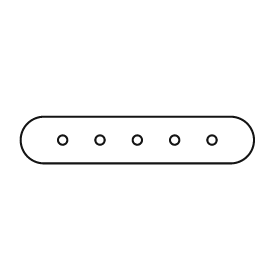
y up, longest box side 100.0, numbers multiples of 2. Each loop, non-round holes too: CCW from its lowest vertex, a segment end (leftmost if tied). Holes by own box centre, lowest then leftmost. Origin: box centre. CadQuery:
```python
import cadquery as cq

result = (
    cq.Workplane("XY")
    .moveTo(-40.0, -10.0)
    .lineTo(40.0, -10.0)
    .threePointArc((50.0, 0.0), (40.0, 10.0))
    .lineTo(-40.0, 10.0)
    .threePointArc((-50.0, 0.0), (-40.0, -10.0))
    .close()
    .moveTo(-32.0, 0.0)
    .circle(2.0)
    .moveTo(-16.0, 0.0)
    .circle(2.0)
    .moveTo(0.0, 0.0)
    .circle(2.0)
    .moveTo(16.0, 0.0)
    .circle(2.0)
    .moveTo(32.0, 0.0)
    .circle(2.0)
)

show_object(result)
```